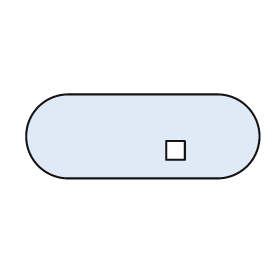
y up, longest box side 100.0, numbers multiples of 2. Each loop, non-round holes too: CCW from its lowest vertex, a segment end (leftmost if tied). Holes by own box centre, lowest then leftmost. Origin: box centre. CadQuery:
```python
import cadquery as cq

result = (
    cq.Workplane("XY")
    .moveTo(-32.0, -18.0)
    .lineTo(32.0, -18.0)
    .threePointArc((50.0, 0.0), (32.0, 18.0))
    .lineTo(-32.0, 18.0)
    .threePointArc((-50.0, 0.0), (-32.0, -18.0))
    .close()
    .moveTo(10.0, -10.0)
    .lineTo(18.0, -10.0)
    .lineTo(18.0, -2.0)
    .lineTo(10.0, -2.0)
    .close()
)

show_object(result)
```